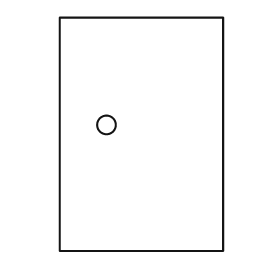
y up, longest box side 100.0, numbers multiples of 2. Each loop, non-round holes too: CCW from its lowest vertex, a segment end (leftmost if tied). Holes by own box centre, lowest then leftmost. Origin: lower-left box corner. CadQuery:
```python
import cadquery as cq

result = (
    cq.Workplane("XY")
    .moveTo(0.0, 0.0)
    .lineTo(70.0, 0.0)
    .lineTo(70.0, 100.0)
    .lineTo(0.0, 100.0)
    .close()
    .moveTo(20.0, 54.0)
    .circle(4.0)
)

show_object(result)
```